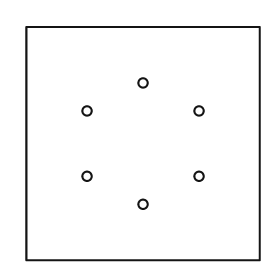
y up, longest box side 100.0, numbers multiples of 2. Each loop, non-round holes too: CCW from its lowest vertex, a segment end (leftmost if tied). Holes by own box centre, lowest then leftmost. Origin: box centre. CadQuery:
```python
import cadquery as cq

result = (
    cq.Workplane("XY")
    .moveTo(-50.0, -50.0)
    .lineTo(50.0, -50.0)
    .lineTo(50.0, 50.0)
    .lineTo(-50.0, 50.0)
    .close()
    .moveTo(0.0, -26.0)
    .circle(2.0)
    .moveTo(-24.0, -14.0)
    .circle(2.0)
    .moveTo(24.0, -14.0)
    .circle(2.0)
    .moveTo(-24.0, 14.0)
    .circle(2.0)
    .moveTo(24.0, 14.0)
    .circle(2.0)
    .moveTo(0.0, 26.0)
    .circle(2.0)
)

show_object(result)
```